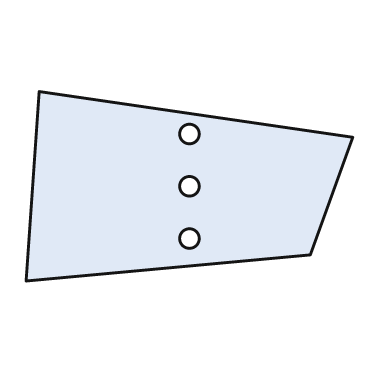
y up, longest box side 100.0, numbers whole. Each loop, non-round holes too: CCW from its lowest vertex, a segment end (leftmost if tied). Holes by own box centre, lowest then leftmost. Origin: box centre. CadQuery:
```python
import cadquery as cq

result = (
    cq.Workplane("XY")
    .moveTo(-50.0, -29.0)
    .lineTo(37.0, -21.0)
    .lineTo(50.0, 15.0)
    .lineTo(-46.0, 29.0)
    .close()
    .moveTo(0.0, -16.0)
    .circle(3.0)
    .moveTo(0.0, 0.0)
    .circle(3.0)
    .moveTo(0.0, 16.0)
    .circle(3.0)
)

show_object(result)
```